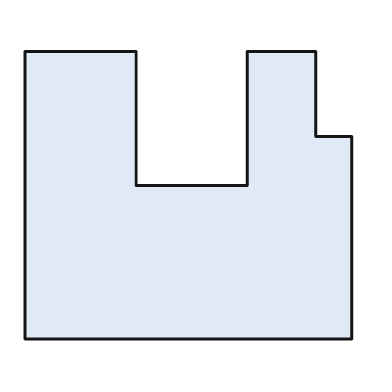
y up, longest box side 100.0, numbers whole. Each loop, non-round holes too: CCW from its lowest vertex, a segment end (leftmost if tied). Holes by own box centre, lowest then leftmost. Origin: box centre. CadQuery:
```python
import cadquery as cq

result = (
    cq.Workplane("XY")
    .moveTo(-50.0, -44.0)
    .lineTo(50.0, -44.0)
    .lineTo(50.0, 18.0)
    .lineTo(39.0, 18.0)
    .lineTo(39.0, 44.0)
    .lineTo(18.0, 44.0)
    .lineTo(18.0, 3.0)
    .lineTo(-16.0, 3.0)
    .lineTo(-16.0, 44.0)
    .lineTo(-50.0, 44.0)
    .close()
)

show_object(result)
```